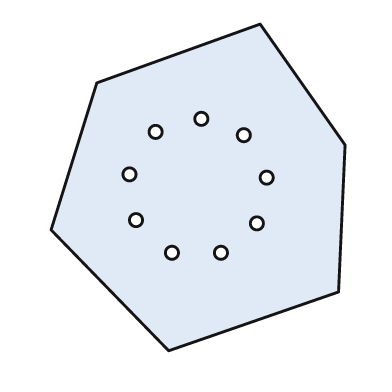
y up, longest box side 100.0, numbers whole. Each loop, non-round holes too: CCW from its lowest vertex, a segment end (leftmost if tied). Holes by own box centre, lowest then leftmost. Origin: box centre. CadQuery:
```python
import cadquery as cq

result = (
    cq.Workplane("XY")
    .moveTo(-9.0, -50.0)
    .lineTo(43.0, -32.0)
    .lineTo(45.0, 13.0)
    .lineTo(19.0, 50.0)
    .lineTo(-31.0, 32.0)
    .lineTo(-45.0, -13.0)
    .close()
    .moveTo(-8.0, -20.0)
    .circle(2.0)
    .moveTo(7.0, -20.0)
    .circle(2.0)
    .moveTo(18.0, -11.0)
    .circle(2.0)
    .moveTo(-19.0, -10.0)
    .circle(2.0)
    .moveTo(21.0, 3.0)
    .circle(2.0)
    .moveTo(-21.0, 4.0)
    .circle(2.0)
    .moveTo(14.0, 16.0)
    .circle(2.0)
    .moveTo(-13.0, 17.0)
    .circle(2.0)
    .moveTo(1.0, 21.0)
    .circle(2.0)
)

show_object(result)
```